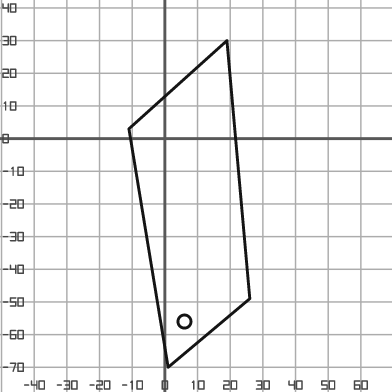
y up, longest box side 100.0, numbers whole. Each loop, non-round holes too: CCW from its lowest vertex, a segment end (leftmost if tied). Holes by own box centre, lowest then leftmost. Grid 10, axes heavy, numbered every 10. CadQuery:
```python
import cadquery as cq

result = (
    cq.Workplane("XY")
    .moveTo(1.0, -70.0)
    .lineTo(26.0, -49.0)
    .lineTo(19.0, 30.0)
    .lineTo(-11.0, 3.0)
    .close()
    .moveTo(6.0, -56.0)
    .circle(2.0)
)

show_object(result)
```